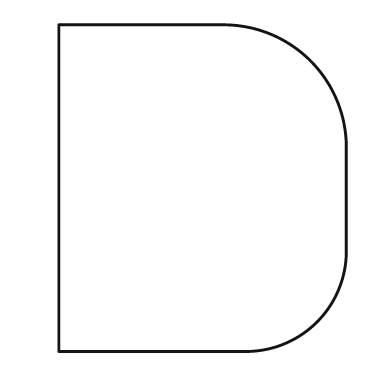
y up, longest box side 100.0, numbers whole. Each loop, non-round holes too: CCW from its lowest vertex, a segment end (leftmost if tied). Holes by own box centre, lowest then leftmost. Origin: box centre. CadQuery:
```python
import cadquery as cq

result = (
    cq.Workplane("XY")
    .moveTo(-44.0, -50.0)
    .lineTo(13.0, -50.0)
    .threePointArc((35.0, -41.0), (44.0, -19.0))
    .lineTo(44.0, 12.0)
    .threePointArc((33.0, 39.0), (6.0, 50.0))
    .lineTo(-44.0, 50.0)
    .close()
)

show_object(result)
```